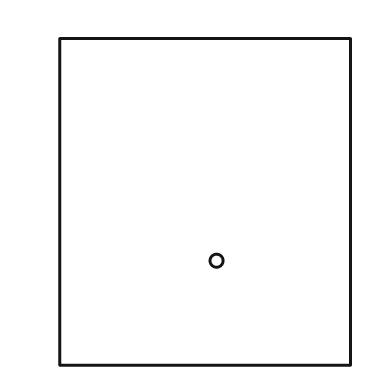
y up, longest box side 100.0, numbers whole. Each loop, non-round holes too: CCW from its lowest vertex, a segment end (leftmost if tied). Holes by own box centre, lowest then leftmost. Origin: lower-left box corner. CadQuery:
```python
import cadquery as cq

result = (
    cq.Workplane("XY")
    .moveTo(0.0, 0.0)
    .lineTo(89.0, 0.0)
    .lineTo(89.0, 100.0)
    .lineTo(0.0, 100.0)
    .close()
    .moveTo(48.0, 32.0)
    .circle(2.0)
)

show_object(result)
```